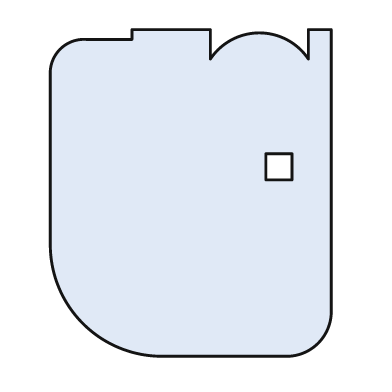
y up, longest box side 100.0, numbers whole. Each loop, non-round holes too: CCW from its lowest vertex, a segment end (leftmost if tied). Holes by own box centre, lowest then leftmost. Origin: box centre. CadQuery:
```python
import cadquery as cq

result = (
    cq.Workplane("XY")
    .moveTo(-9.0, -50.0)
    .lineTo(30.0, -50.0)
    .threePointArc((39.0, -46.0), (43.0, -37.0))
    .lineTo(43.0, 50.0)
    .lineTo(36.0, 50.0)
    .lineTo(36.0, 41.0)
    .threePointArc((21.0, 49.0), (6.0, 41.0))
    .lineTo(6.0, 50.0)
    .lineTo(-18.0, 50.0)
    .lineTo(-18.0, 47.0)
    .lineTo(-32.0, 47.0)
    .threePointArc((-40.0, 44.0), (-43.0, 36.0))
    .lineTo(-43.0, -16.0)
    .threePointArc((-33.0, -40.0), (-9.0, -50.0))
    .close()
    .moveTo(23.0, 4.0)
    .lineTo(31.0, 4.0)
    .lineTo(31.0, 12.0)
    .lineTo(23.0, 12.0)
    .close()
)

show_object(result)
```